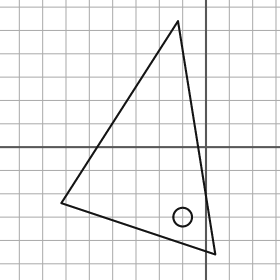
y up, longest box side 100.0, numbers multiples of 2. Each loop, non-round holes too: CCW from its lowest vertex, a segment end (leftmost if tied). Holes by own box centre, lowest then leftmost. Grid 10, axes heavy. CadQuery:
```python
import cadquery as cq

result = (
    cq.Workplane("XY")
    .moveTo(4.0, -46.0)
    .lineTo(-12.0, 54.0)
    .lineTo(-62.0, -24.0)
    .close()
    .moveTo(-10.0, -30.0)
    .circle(4.0)
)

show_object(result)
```